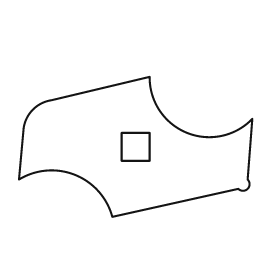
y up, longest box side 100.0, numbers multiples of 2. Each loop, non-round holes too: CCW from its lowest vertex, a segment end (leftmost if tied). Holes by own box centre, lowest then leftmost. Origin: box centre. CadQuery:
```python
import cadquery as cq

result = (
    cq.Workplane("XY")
    .moveTo(-10.0, -30.0)
    .lineTo(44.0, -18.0)
    .threePointArc((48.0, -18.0), (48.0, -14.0))
    .lineTo(50.0, 12.0)
    .threePointArc((22.0, 6.0), (6.0, 30.0))
    .lineTo(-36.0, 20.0)
    .threePointArc((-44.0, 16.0), (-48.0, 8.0))
    .lineTo(-50.0, -14.0)
    .threePointArc((-26.0, -12.0), (-10.0, -30.0))
    .close()
    .moveTo(-6.0, -6.0)
    .lineTo(6.0, -6.0)
    .lineTo(6.0, 6.0)
    .lineTo(-6.0, 6.0)
    .close()
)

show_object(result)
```